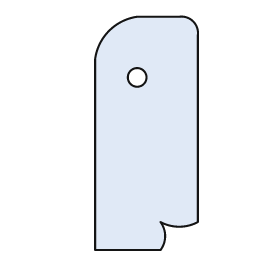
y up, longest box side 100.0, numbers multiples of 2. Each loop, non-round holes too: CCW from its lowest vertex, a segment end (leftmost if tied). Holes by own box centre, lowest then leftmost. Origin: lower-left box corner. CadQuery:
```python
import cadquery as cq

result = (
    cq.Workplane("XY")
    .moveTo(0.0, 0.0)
    .lineTo(28.0, 0.0)
    .threePointArc((30.0, 6.0), (28.0, 12.0))
    .threePointArc((36.0, 10.0), (44.0, 12.0))
    .lineTo(44.0, 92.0)
    .threePointArc((42.0, 98.0), (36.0, 100.0))
    .lineTo(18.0, 100.0)
    .threePointArc((6.0, 94.0), (0.0, 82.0))
    .close()
    .moveTo(18.0, 74.0)
    .circle(4.0)
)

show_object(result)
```